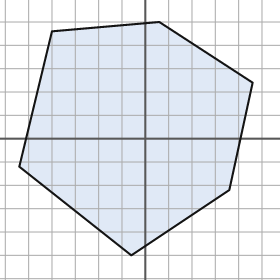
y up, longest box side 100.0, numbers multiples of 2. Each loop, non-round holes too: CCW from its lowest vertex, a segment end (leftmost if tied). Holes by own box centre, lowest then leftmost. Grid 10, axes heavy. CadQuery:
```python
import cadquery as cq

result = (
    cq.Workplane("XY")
    .moveTo(-6.0, -50.0)
    .lineTo(36.0, -22.0)
    .lineTo(46.0, 24.0)
    .lineTo(6.0, 50.0)
    .lineTo(-40.0, 46.0)
    .lineTo(-54.0, -12.0)
    .close()
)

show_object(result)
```